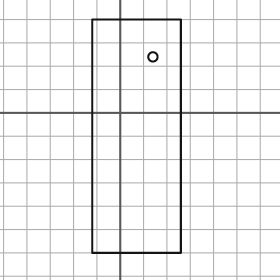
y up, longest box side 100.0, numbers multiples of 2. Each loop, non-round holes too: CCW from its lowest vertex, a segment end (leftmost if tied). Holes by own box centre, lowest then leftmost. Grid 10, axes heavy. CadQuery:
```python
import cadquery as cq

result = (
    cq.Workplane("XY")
    .moveTo(-12.0, -60.0)
    .lineTo(26.0, -60.0)
    .lineTo(26.0, 40.0)
    .lineTo(-12.0, 40.0)
    .close()
    .moveTo(14.0, 24.0)
    .circle(2.0)
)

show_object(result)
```